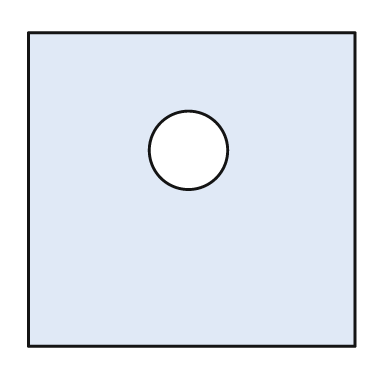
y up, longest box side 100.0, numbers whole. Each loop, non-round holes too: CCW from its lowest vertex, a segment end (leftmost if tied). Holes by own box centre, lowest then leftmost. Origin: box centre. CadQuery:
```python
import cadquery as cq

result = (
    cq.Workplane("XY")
    .moveTo(-50.0, -48.0)
    .lineTo(50.0, -48.0)
    .lineTo(50.0, 48.0)
    .lineTo(-50.0, 48.0)
    .close()
    .moveTo(-1.0, 12.0)
    .circle(12.0)
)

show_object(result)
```